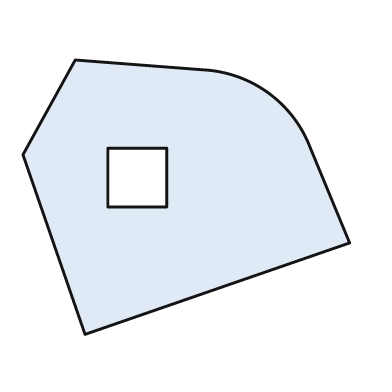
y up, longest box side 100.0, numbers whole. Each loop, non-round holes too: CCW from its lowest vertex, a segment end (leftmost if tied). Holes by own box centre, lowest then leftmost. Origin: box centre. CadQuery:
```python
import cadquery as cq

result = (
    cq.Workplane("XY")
    .moveTo(-31.0, -42.0)
    .lineTo(50.0, -14.0)
    .lineTo(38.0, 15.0)
    .threePointArc((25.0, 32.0), (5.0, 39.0))
    .lineTo(-34.0, 42.0)
    .lineTo(-50.0, 13.0)
    .close()
    .moveTo(-24.0, -3.0)
    .lineTo(-6.0, -3.0)
    .lineTo(-6.0, 15.0)
    .lineTo(-24.0, 15.0)
    .close()
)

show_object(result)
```